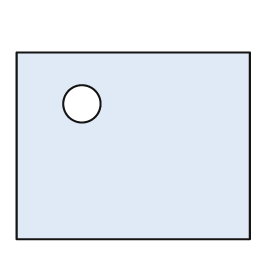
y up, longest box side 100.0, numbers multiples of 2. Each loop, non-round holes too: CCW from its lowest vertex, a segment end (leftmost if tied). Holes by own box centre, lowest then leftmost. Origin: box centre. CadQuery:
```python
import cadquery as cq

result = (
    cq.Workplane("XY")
    .moveTo(-50.0, -40.0)
    .lineTo(50.0, -40.0)
    .lineTo(50.0, 40.0)
    .lineTo(-50.0, 40.0)
    .close()
    .moveTo(-22.0, 18.0)
    .circle(8.0)
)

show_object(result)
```